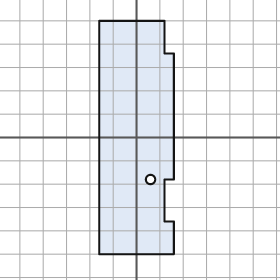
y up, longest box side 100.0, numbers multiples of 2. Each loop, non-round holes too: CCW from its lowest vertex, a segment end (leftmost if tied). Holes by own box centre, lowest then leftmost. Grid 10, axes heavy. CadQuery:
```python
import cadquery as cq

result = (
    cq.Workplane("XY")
    .moveTo(-16.0, -50.0)
    .lineTo(16.0, -50.0)
    .lineTo(16.0, -36.0)
    .lineTo(12.0, -36.0)
    .lineTo(12.0, -18.0)
    .lineTo(16.0, -18.0)
    .lineTo(16.0, 36.0)
    .lineTo(12.0, 36.0)
    .lineTo(12.0, 50.0)
    .lineTo(-16.0, 50.0)
    .close()
    .moveTo(6.0, -18.0)
    .circle(2.0)
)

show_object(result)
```